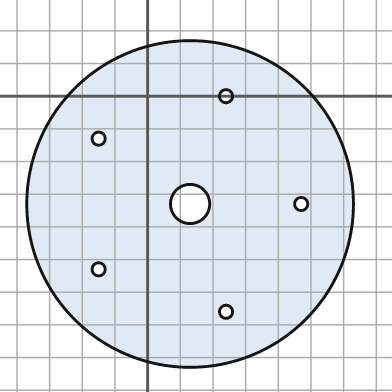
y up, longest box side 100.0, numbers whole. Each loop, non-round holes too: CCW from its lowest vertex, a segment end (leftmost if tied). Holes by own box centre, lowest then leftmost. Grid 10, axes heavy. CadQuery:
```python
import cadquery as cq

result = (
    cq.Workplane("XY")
    .moveTo(13.0, -33.0)
    .circle(50.0)
    .moveTo(24.0, -66.0)
    .circle(2.0)
    .moveTo(-15.0, -53.0)
    .circle(2.0)
    .moveTo(13.0, -33.0)
    .circle(6.0)
    .moveTo(47.0, -33.0)
    .circle(2.0)
    .moveTo(-15.0, -13.0)
    .circle(2.0)
    .moveTo(24.0, 0.0)
    .circle(2.0)
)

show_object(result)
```